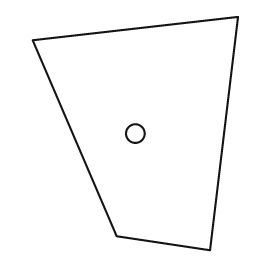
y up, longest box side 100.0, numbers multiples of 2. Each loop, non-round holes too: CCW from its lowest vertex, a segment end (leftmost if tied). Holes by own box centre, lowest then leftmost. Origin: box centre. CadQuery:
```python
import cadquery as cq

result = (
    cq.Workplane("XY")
    .moveTo(32.0, -50.0)
    .lineTo(44.0, 50.0)
    .lineTo(-44.0, 40.0)
    .lineTo(-8.0, -44.0)
    .close()
    .moveTo(0.0, 0.0)
    .circle(4.0)
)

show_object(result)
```